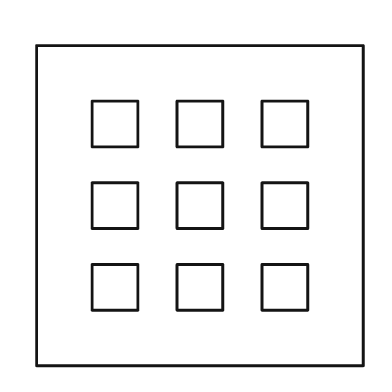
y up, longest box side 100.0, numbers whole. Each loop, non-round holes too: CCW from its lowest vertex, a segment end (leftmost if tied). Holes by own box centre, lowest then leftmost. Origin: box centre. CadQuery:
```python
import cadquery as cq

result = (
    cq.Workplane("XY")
    .moveTo(-50.0, -49.0)
    .lineTo(50.0, -49.0)
    .lineTo(50.0, 49.0)
    .lineTo(-50.0, 49.0)
    .close()
    .moveTo(-33.0, -32.0)
    .lineTo(-19.0, -32.0)
    .lineTo(-19.0, -18.0)
    .lineTo(-33.0, -18.0)
    .close()
    .moveTo(-7.0, -32.0)
    .lineTo(7.0, -32.0)
    .lineTo(7.0, -18.0)
    .lineTo(-7.0, -18.0)
    .close()
    .moveTo(19.0, -32.0)
    .lineTo(33.0, -32.0)
    .lineTo(33.0, -18.0)
    .lineTo(19.0, -18.0)
    .close()
    .moveTo(-33.0, -7.0)
    .lineTo(-19.0, -7.0)
    .lineTo(-19.0, 7.0)
    .lineTo(-33.0, 7.0)
    .close()
    .moveTo(-7.0, -7.0)
    .lineTo(7.0, -7.0)
    .lineTo(7.0, 7.0)
    .lineTo(-7.0, 7.0)
    .close()
    .moveTo(19.0, -7.0)
    .lineTo(33.0, -7.0)
    .lineTo(33.0, 7.0)
    .lineTo(19.0, 7.0)
    .close()
    .moveTo(-33.0, 18.0)
    .lineTo(-19.0, 18.0)
    .lineTo(-19.0, 32.0)
    .lineTo(-33.0, 32.0)
    .close()
    .moveTo(-7.0, 18.0)
    .lineTo(7.0, 18.0)
    .lineTo(7.0, 32.0)
    .lineTo(-7.0, 32.0)
    .close()
    .moveTo(19.0, 18.0)
    .lineTo(33.0, 18.0)
    .lineTo(33.0, 32.0)
    .lineTo(19.0, 32.0)
    .close()
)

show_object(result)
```